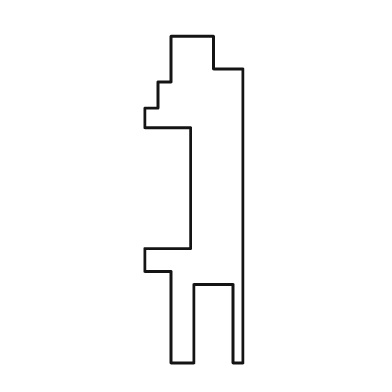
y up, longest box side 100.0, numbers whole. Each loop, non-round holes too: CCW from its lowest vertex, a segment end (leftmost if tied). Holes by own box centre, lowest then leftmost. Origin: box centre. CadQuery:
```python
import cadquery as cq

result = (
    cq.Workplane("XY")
    .moveTo(-7.0, -50.0)
    .lineTo(0.0, -50.0)
    .lineTo(0.0, -26.0)
    .lineTo(12.0, -26.0)
    .lineTo(12.0, -50.0)
    .lineTo(15.0, -50.0)
    .lineTo(15.0, 40.0)
    .lineTo(6.0, 40.0)
    .lineTo(6.0, 50.0)
    .lineTo(-7.0, 50.0)
    .lineTo(-7.0, 36.0)
    .lineTo(-11.0, 36.0)
    .lineTo(-11.0, 28.0)
    .lineTo(-15.0, 28.0)
    .lineTo(-15.0, 22.0)
    .lineTo(-1.0, 22.0)
    .lineTo(-1.0, -15.0)
    .lineTo(-15.0, -15.0)
    .lineTo(-15.0, -22.0)
    .lineTo(-7.0, -22.0)
    .close()
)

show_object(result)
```